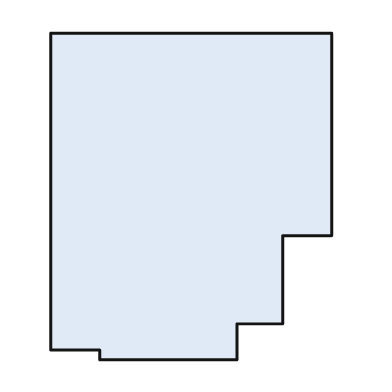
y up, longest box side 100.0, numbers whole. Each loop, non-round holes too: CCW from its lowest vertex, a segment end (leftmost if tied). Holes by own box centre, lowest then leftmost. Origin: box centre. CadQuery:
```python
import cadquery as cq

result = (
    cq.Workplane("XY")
    .moveTo(-28.0, -50.0)
    .lineTo(14.0, -50.0)
    .lineTo(14.0, -39.0)
    .lineTo(28.0, -39.0)
    .lineTo(28.0, -12.0)
    .lineTo(43.0, -12.0)
    .lineTo(43.0, 50.0)
    .lineTo(-43.0, 50.0)
    .lineTo(-43.0, -47.0)
    .lineTo(-28.0, -47.0)
    .close()
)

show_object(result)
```